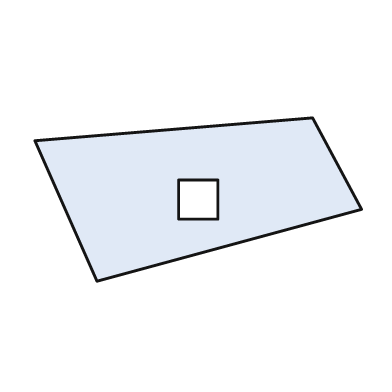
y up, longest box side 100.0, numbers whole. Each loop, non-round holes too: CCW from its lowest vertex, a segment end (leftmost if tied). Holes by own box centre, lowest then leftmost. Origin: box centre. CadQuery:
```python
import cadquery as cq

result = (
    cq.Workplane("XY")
    .moveTo(-31.0, -25.0)
    .lineTo(50.0, -3.0)
    .lineTo(35.0, 25.0)
    .lineTo(-50.0, 18.0)
    .close()
    .moveTo(-6.0, -6.0)
    .lineTo(6.0, -6.0)
    .lineTo(6.0, 6.0)
    .lineTo(-6.0, 6.0)
    .close()
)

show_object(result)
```